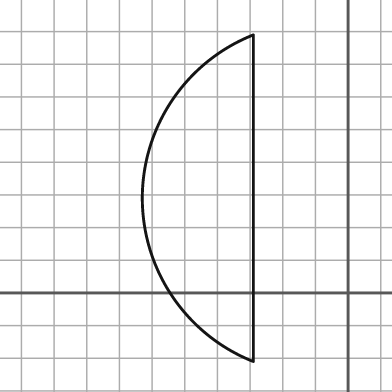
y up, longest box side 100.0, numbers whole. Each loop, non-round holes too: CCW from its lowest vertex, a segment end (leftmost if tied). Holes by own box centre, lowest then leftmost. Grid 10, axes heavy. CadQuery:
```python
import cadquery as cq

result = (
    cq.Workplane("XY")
    .moveTo(-29.0, -21.0)
    .lineTo(-29.0, 79.0)
    .threePointArc((-63.0, 29.0), (-29.0, -21.0))
    .close()
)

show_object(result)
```